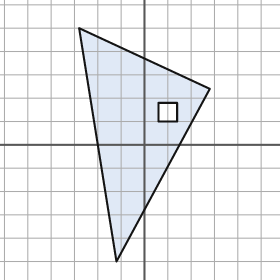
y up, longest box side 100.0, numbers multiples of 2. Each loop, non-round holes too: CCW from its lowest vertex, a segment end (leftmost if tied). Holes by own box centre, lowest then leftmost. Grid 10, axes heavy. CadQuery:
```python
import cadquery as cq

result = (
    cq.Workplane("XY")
    .moveTo(-12.0, -50.0)
    .lineTo(28.0, 24.0)
    .lineTo(-28.0, 50.0)
    .close()
    .moveTo(6.0, 10.0)
    .lineTo(14.0, 10.0)
    .lineTo(14.0, 18.0)
    .lineTo(6.0, 18.0)
    .close()
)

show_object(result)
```